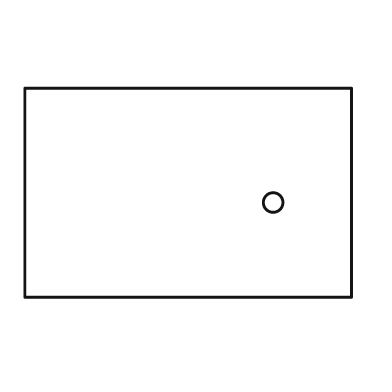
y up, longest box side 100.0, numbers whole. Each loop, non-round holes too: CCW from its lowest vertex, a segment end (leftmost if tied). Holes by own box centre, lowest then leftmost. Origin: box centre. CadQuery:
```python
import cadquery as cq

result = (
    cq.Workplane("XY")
    .moveTo(-50.0, -32.0)
    .lineTo(50.0, -32.0)
    .lineTo(50.0, 32.0)
    .lineTo(-50.0, 32.0)
    .close()
    .moveTo(26.0, -3.0)
    .circle(3.0)
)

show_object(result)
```